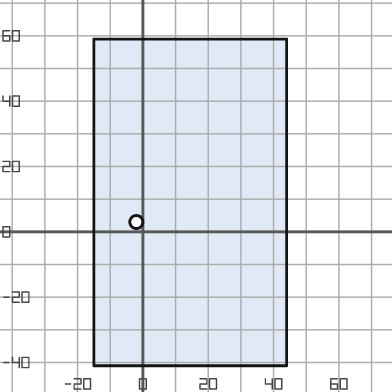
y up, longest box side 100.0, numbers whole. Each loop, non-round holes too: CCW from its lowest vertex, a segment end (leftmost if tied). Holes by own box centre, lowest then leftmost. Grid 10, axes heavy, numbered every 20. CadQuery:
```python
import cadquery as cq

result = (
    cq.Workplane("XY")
    .moveTo(-15.0, -41.0)
    .lineTo(44.0, -41.0)
    .lineTo(44.0, 59.0)
    .lineTo(-15.0, 59.0)
    .close()
    .moveTo(-2.0, 3.0)
    .circle(2.0)
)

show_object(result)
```